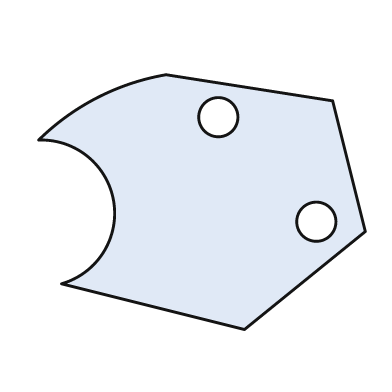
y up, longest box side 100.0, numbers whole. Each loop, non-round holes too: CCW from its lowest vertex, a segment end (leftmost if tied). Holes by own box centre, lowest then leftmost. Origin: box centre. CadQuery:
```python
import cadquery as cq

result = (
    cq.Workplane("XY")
    .moveTo(13.0, -39.0)
    .lineTo(50.0, -9.0)
    .lineTo(40.0, 31.0)
    .lineTo(-11.0, 39.0)
    .threePointArc((-32.0, 32.0), (-50.0, 19.0))
    .threePointArc((-27.0, 0.0), (-43.0, -25.0))
    .close()
    .moveTo(35.0, -6.0)
    .circle(6.0)
    .moveTo(5.0, 26.0)
    .circle(6.0)
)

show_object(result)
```